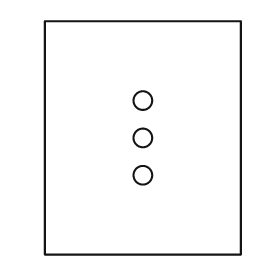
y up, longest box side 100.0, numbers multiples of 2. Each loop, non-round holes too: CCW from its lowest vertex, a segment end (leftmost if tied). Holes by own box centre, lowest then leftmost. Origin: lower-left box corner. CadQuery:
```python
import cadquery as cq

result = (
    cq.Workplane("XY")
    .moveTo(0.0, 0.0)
    .lineTo(84.0, 0.0)
    .lineTo(84.0, 100.0)
    .lineTo(0.0, 100.0)
    .close()
    .moveTo(42.0, 34.0)
    .circle(4.0)
    .moveTo(42.0, 50.0)
    .circle(4.0)
    .moveTo(42.0, 66.0)
    .circle(4.0)
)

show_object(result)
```